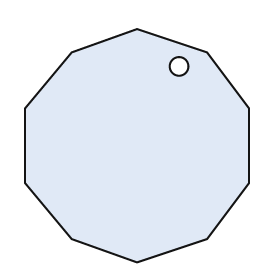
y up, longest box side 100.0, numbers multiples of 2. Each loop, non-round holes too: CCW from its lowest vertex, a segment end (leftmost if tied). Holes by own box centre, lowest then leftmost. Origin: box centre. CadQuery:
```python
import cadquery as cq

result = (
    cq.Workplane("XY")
    .moveTo(0.0, -50.0)
    .lineTo(30.0, -40.0)
    .lineTo(48.0, -16.0)
    .lineTo(48.0, 16.0)
    .lineTo(30.0, 40.0)
    .lineTo(0.0, 50.0)
    .lineTo(-28.0, 40.0)
    .lineTo(-48.0, 16.0)
    .lineTo(-48.0, -16.0)
    .lineTo(-28.0, -40.0)
    .close()
    .moveTo(18.0, 34.0)
    .circle(4.0)
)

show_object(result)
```